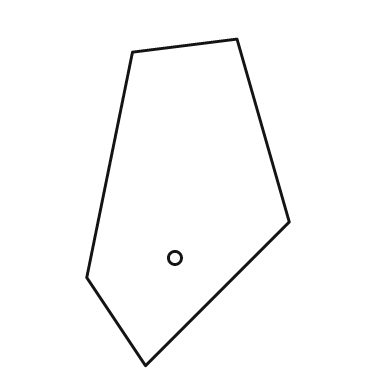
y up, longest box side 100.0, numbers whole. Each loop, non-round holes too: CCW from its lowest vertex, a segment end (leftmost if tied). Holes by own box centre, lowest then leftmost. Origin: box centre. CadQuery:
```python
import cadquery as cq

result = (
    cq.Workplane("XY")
    .moveTo(-13.0, -50.0)
    .lineTo(31.0, -6.0)
    .lineTo(15.0, 50.0)
    .lineTo(-17.0, 46.0)
    .lineTo(-31.0, -23.0)
    .close()
    .moveTo(-4.0, -17.0)
    .circle(2.0)
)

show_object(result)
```